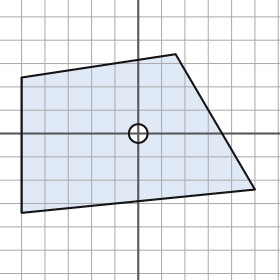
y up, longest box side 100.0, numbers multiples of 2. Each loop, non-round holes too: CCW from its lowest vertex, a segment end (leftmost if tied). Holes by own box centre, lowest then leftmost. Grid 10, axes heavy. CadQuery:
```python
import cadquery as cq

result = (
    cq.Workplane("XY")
    .moveTo(-50.0, -34.0)
    .lineTo(50.0, -24.0)
    .lineTo(16.0, 34.0)
    .lineTo(-50.0, 24.0)
    .close()
    .moveTo(0.0, 0.0)
    .circle(4.0)
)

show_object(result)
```